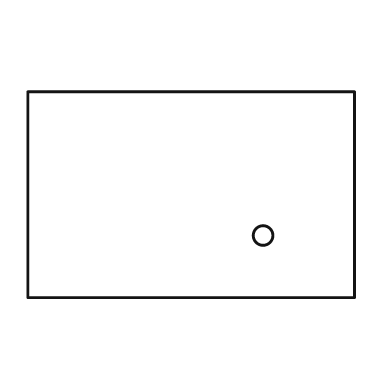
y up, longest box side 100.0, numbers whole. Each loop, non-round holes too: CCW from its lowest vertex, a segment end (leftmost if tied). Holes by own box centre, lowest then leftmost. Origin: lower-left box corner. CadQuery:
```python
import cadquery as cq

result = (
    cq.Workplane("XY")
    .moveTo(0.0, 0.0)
    .lineTo(100.0, 0.0)
    .lineTo(100.0, 63.0)
    .lineTo(0.0, 63.0)
    .close()
    .moveTo(72.0, 19.0)
    .circle(3.0)
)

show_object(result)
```